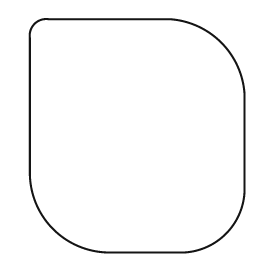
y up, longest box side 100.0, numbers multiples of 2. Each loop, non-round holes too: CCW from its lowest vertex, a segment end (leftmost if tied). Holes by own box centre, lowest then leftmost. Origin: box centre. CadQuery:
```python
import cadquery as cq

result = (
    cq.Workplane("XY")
    .moveTo(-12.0, -50.0)
    .lineTo(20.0, -50.0)
    .threePointArc((38.0, -42.0), (46.0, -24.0))
    .lineTo(46.0, 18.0)
    .threePointArc((36.0, 40.0), (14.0, 50.0))
    .lineTo(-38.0, 50.0)
    .threePointArc((-44.0, 48.0), (-46.0, 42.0))
    .lineTo(-46.0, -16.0)
    .threePointArc((-36.0, -40.0), (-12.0, -50.0))
    .close()
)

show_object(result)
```